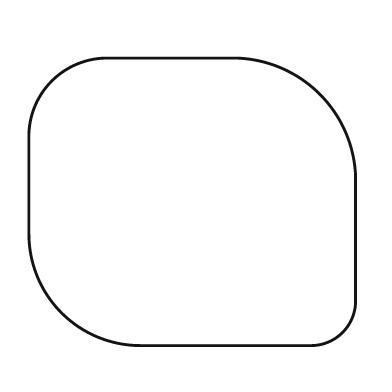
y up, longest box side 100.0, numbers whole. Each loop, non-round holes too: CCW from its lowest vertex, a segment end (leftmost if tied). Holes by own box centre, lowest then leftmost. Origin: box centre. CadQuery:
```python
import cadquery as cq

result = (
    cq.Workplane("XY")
    .moveTo(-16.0, -44.0)
    .lineTo(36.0, -44.0)
    .threePointArc((46.0, -40.0), (50.0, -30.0))
    .lineTo(50.0, 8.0)
    .threePointArc((39.0, 33.0), (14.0, 44.0))
    .lineTo(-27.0, 44.0)
    .threePointArc((-43.0, 37.0), (-50.0, 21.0))
    .lineTo(-50.0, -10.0)
    .threePointArc((-40.0, -34.0), (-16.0, -44.0))
    .close()
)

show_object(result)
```